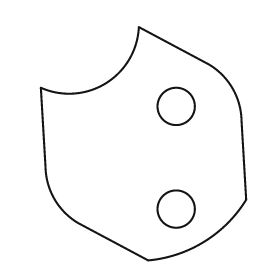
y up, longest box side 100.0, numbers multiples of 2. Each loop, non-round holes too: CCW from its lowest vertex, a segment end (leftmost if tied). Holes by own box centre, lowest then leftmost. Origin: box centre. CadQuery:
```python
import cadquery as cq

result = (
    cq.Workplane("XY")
    .moveTo(2.0, -50.0)
    .threePointArc((26.0, -42.0), (44.0, -24.0))
    .lineTo(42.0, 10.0)
    .threePointArc((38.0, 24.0), (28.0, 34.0))
    .lineTo(-2.0, 50.0)
    .threePointArc((-16.0, 26.0), (-44.0, 24.0))
    .lineTo(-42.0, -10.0)
    .threePointArc((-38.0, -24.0), (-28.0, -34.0))
    .close()
    .moveTo(14.0, -28.0)
    .circle(8.0)
    .moveTo(14.0, 16.0)
    .circle(8.0)
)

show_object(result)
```